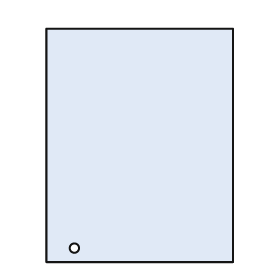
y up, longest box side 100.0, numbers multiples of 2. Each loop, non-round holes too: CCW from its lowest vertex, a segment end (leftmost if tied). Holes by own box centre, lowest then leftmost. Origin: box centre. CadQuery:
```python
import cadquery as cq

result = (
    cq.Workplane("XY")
    .moveTo(-40.0, -50.0)
    .lineTo(40.0, -50.0)
    .lineTo(40.0, 50.0)
    .lineTo(-40.0, 50.0)
    .close()
    .moveTo(-28.0, -44.0)
    .circle(2.0)
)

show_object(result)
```